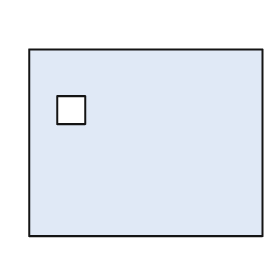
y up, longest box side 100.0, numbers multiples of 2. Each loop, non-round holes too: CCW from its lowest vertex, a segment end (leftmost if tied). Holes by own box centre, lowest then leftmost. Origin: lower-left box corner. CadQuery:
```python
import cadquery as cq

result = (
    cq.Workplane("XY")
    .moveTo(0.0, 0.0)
    .lineTo(100.0, 0.0)
    .lineTo(100.0, 80.0)
    .lineTo(0.0, 80.0)
    .close()
    .moveTo(12.0, 48.0)
    .lineTo(24.0, 48.0)
    .lineTo(24.0, 60.0)
    .lineTo(12.0, 60.0)
    .close()
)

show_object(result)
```